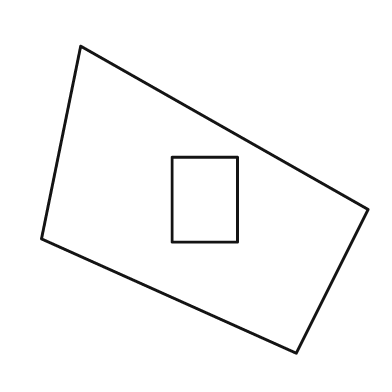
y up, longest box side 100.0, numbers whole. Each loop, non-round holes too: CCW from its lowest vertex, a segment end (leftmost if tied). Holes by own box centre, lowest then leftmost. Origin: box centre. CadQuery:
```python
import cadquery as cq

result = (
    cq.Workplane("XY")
    .moveTo(28.0, -47.0)
    .lineTo(50.0, -3.0)
    .lineTo(-38.0, 47.0)
    .lineTo(-50.0, -12.0)
    .close()
    .moveTo(-10.0, -13.0)
    .lineTo(10.0, -13.0)
    .lineTo(10.0, 13.0)
    .lineTo(-10.0, 13.0)
    .close()
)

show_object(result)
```